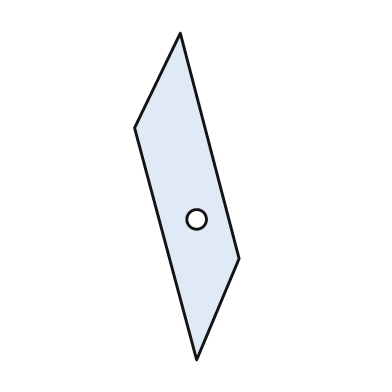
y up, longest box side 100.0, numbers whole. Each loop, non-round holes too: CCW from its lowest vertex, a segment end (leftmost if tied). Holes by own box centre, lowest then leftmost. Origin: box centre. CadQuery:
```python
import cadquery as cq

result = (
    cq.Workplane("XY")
    .moveTo(3.0, -50.0)
    .lineTo(16.0, -19.0)
    .lineTo(-2.0, 50.0)
    .lineTo(-16.0, 21.0)
    .close()
    .moveTo(3.0, -7.0)
    .circle(3.0)
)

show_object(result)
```